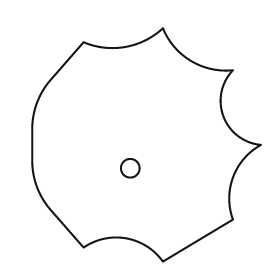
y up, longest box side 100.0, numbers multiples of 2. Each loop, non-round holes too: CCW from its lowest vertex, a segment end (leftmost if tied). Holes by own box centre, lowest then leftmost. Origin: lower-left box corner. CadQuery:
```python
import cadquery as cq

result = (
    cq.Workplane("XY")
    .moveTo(56.0, 0.0)
    .lineTo(86.0, 18.0)
    .threePointArc((86.0, 36.0), (98.0, 50.0))
    .threePointArc((82.0, 62.0), (86.0, 82.0))
    .threePointArc((68.0, 86.0), (56.0, 100.0))
    .threePointArc((40.0, 92.0), (22.0, 94.0))
    .lineTo(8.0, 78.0)
    .threePointArc((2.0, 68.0), (0.0, 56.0))
    .lineTo(0.0, 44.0)
    .threePointArc((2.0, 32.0), (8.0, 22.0))
    .lineTo(22.0, 6.0)
    .threePointArc((40.0, 10.0), (56.0, 0.0))
    .close()
    .moveTo(42.0, 40.0)
    .circle(4.0)
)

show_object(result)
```